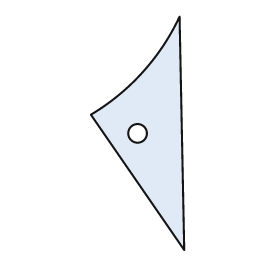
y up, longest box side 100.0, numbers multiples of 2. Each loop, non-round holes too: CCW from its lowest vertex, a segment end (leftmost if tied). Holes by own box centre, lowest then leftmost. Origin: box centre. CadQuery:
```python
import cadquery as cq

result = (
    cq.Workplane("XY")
    .moveTo(20.0, -50.0)
    .lineTo(18.0, 50.0)
    .threePointArc((2.0, 26.0), (-20.0, 8.0))
    .close()
    .moveTo(0.0, 0.0)
    .circle(4.0)
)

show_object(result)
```